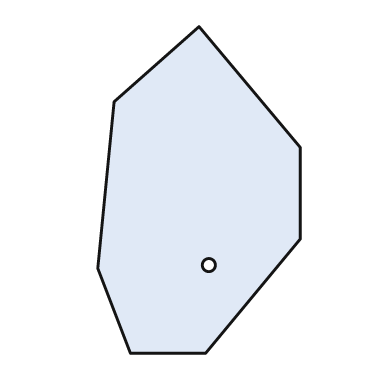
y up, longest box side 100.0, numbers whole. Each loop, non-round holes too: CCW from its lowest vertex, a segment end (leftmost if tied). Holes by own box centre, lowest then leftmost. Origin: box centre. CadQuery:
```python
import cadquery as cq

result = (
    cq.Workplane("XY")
    .moveTo(-21.0, -50.0)
    .lineTo(2.0, -50.0)
    .lineTo(31.0, -15.0)
    .lineTo(31.0, 13.0)
    .lineTo(0.0, 50.0)
    .lineTo(-26.0, 27.0)
    .lineTo(-31.0, -24.0)
    .close()
    .moveTo(3.0, -23.0)
    .circle(2.0)
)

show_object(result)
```